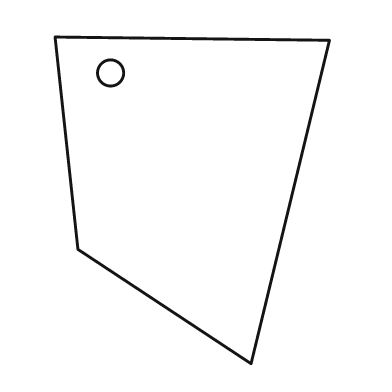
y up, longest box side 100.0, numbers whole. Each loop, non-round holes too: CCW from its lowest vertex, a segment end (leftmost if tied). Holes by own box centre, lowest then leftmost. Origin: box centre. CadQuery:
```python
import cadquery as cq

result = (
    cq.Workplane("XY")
    .moveTo(18.0, -50.0)
    .lineTo(42.0, 49.0)
    .lineTo(-42.0, 50.0)
    .lineTo(-35.0, -15.0)
    .close()
    .moveTo(-25.0, 39.0)
    .circle(4.0)
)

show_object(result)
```